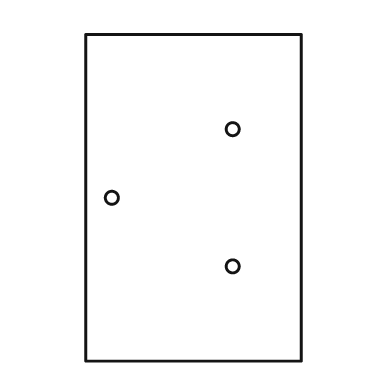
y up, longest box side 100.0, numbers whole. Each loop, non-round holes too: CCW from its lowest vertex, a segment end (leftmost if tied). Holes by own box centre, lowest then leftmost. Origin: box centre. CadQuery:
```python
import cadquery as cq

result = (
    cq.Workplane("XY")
    .moveTo(-33.0, -50.0)
    .lineTo(33.0, -50.0)
    .lineTo(33.0, 50.0)
    .lineTo(-33.0, 50.0)
    .close()
    .moveTo(12.0, -21.0)
    .circle(2.0)
    .moveTo(-25.0, 0.0)
    .circle(2.0)
    .moveTo(12.0, 21.0)
    .circle(2.0)
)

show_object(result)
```